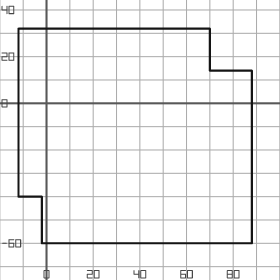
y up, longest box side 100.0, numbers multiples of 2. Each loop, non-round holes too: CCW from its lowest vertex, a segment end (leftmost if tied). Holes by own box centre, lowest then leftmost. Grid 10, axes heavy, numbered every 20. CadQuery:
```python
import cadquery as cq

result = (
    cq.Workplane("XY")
    .moveTo(-2.0, -60.0)
    .lineTo(88.0, -60.0)
    .lineTo(88.0, 14.0)
    .lineTo(70.0, 14.0)
    .lineTo(70.0, 32.0)
    .lineTo(-12.0, 32.0)
    .lineTo(-12.0, -40.0)
    .lineTo(-2.0, -40.0)
    .close()
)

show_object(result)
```